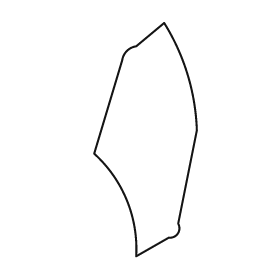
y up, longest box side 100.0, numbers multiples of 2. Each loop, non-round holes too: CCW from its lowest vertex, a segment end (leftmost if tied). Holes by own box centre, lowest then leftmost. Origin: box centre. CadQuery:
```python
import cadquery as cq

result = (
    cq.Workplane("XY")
    .moveTo(-4.0, -50.0)
    .lineTo(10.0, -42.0)
    .threePointArc((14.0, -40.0), (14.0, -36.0))
    .lineTo(22.0, 4.0)
    .threePointArc((18.0, 28.0), (8.0, 50.0))
    .lineTo(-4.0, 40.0)
    .threePointArc((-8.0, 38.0), (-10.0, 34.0))
    .lineTo(-22.0, -6.0)
    .threePointArc((-8.0, -26.0), (-4.0, -50.0))
    .close()
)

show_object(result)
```